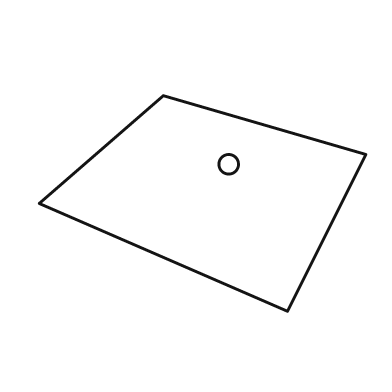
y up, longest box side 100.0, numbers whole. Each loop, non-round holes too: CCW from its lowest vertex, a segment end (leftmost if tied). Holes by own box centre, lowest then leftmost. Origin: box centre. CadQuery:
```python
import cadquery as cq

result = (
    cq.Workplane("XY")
    .moveTo(26.0, -33.0)
    .lineTo(50.0, 15.0)
    .lineTo(-12.0, 33.0)
    .lineTo(-50.0, 0.0)
    .close()
    .moveTo(8.0, 12.0)
    .circle(3.0)
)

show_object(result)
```